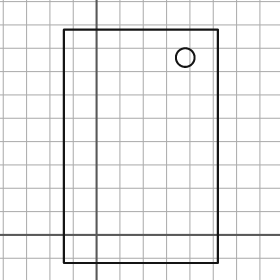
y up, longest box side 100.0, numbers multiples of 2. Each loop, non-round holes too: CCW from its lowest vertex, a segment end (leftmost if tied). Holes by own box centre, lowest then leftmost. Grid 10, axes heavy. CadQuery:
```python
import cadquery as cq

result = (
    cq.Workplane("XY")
    .moveTo(-14.0, -12.0)
    .lineTo(52.0, -12.0)
    .lineTo(52.0, 88.0)
    .lineTo(-14.0, 88.0)
    .close()
    .moveTo(38.0, 76.0)
    .circle(4.0)
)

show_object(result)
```